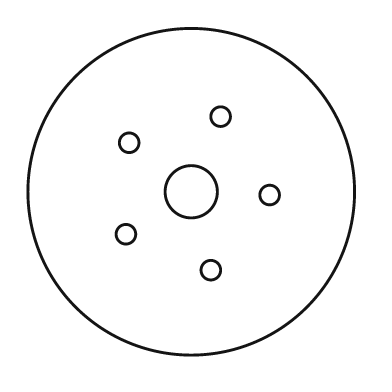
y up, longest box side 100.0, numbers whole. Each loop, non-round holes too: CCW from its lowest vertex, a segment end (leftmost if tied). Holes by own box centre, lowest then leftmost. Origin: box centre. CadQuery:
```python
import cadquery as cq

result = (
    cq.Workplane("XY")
    .moveTo(0.0, 0.0)
    .circle(50.0)
    .moveTo(6.0, -24.0)
    .circle(3.0)
    .moveTo(-20.0, -13.0)
    .circle(3.0)
    .moveTo(24.0, -1.0)
    .circle(3.0)
    .moveTo(0.0, 0.0)
    .circle(8.0)
    .moveTo(-19.0, 15.0)
    .circle(3.0)
    .moveTo(9.0, 23.0)
    .circle(3.0)
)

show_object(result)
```